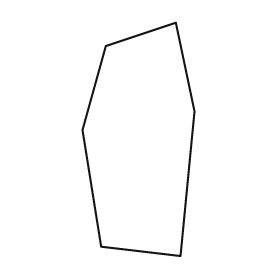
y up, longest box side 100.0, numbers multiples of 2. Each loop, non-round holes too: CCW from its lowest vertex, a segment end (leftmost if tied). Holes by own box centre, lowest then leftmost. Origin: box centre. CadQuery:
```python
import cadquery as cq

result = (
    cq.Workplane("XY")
    .moveTo(18.0, -50.0)
    .lineTo(24.0, 12.0)
    .lineTo(16.0, 50.0)
    .lineTo(-14.0, 40.0)
    .lineTo(-24.0, 4.0)
    .lineTo(-16.0, -46.0)
    .close()
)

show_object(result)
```